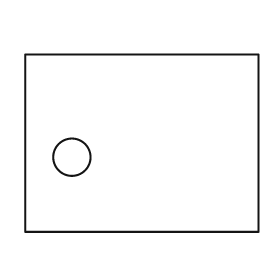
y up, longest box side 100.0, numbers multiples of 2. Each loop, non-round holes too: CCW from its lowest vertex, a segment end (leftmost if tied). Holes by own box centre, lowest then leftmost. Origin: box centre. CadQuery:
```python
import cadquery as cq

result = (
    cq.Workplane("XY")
    .moveTo(-50.0, -38.0)
    .lineTo(50.0, -38.0)
    .lineTo(50.0, 38.0)
    .lineTo(-50.0, 38.0)
    .close()
    .moveTo(-30.0, -6.0)
    .circle(8.0)
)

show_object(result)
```